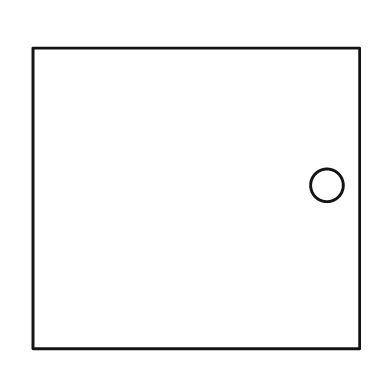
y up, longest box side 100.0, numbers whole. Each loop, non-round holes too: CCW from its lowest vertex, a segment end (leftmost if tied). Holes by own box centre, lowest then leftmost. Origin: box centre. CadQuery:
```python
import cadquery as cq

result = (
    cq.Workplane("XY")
    .moveTo(-50.0, -46.0)
    .lineTo(50.0, -46.0)
    .lineTo(50.0, 46.0)
    .lineTo(-50.0, 46.0)
    .close()
    .moveTo(40.0, 4.0)
    .circle(5.0)
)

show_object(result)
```